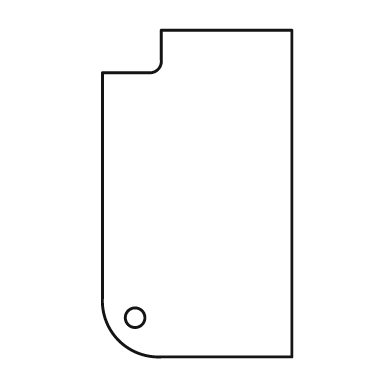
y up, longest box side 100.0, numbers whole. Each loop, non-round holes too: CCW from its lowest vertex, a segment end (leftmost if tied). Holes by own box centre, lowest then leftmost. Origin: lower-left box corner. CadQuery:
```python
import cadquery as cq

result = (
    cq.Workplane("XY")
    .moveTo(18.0, 0.0)
    .lineTo(58.0, 0.0)
    .lineTo(58.0, 100.0)
    .lineTo(18.0, 100.0)
    .lineTo(18.0, 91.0)
    .threePointArc((17.0, 88.0), (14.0, 87.0))
    .lineTo(0.0, 87.0)
    .lineTo(0.0, 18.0)
    .threePointArc((5.0, 5.0), (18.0, 0.0))
    .close()
    .moveTo(10.0, 12.0)
    .circle(3.0)
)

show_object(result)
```